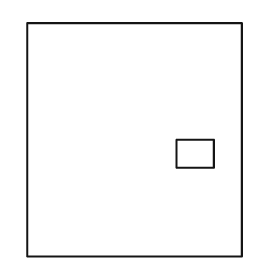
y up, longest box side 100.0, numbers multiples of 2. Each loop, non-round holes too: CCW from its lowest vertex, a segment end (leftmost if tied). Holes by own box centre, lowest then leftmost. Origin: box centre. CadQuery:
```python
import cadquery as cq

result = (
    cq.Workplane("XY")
    .moveTo(-46.0, -50.0)
    .lineTo(46.0, -50.0)
    .lineTo(46.0, 50.0)
    .lineTo(-46.0, 50.0)
    .close()
    .moveTo(18.0, -12.0)
    .lineTo(34.0, -12.0)
    .lineTo(34.0, 0.0)
    .lineTo(18.0, 0.0)
    .close()
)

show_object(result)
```